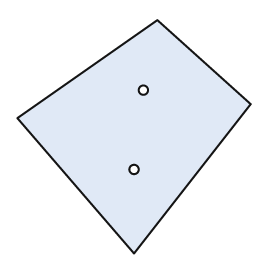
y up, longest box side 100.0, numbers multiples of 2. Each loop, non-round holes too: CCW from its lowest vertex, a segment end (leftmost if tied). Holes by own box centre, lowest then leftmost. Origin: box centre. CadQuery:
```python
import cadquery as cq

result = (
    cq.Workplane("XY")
    .moveTo(0.0, -50.0)
    .lineTo(50.0, 14.0)
    .lineTo(10.0, 50.0)
    .lineTo(-50.0, 8.0)
    .close()
    .moveTo(0.0, -14.0)
    .circle(2.0)
    .moveTo(4.0, 20.0)
    .circle(2.0)
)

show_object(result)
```